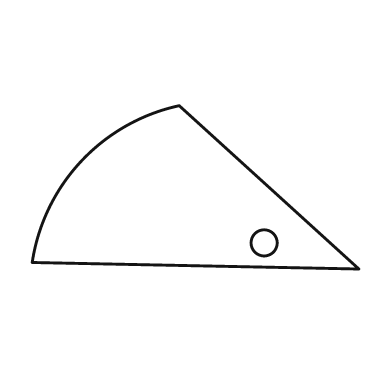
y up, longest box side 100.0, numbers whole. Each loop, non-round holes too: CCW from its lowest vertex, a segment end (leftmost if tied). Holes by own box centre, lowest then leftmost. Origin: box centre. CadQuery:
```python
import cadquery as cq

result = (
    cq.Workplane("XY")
    .moveTo(50.0, -25.0)
    .lineTo(-5.0, 25.0)
    .threePointArc((-35.0, 8.0), (-50.0, -23.0))
    .close()
    .moveTo(21.0, -17.0)
    .circle(4.0)
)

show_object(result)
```